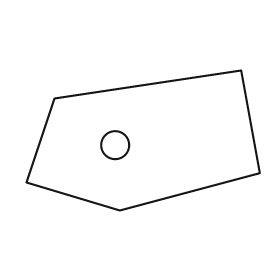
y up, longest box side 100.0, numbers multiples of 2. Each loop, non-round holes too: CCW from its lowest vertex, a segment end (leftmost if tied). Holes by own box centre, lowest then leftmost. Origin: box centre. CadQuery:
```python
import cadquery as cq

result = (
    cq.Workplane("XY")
    .moveTo(-10.0, -30.0)
    .lineTo(50.0, -14.0)
    .lineTo(42.0, 30.0)
    .lineTo(-38.0, 18.0)
    .lineTo(-50.0, -18.0)
    .close()
    .moveTo(-12.0, -2.0)
    .circle(6.0)
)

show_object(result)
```